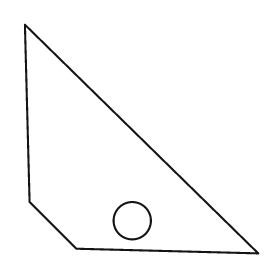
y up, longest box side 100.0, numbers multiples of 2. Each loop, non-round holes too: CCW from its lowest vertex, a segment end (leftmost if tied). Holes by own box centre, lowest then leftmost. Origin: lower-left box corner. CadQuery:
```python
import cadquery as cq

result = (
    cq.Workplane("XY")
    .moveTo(100.0, 0.0)
    .lineTo(0.0, 98.0)
    .lineTo(2.0, 22.0)
    .lineTo(22.0, 2.0)
    .close()
    .moveTo(46.0, 14.0)
    .circle(8.0)
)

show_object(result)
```